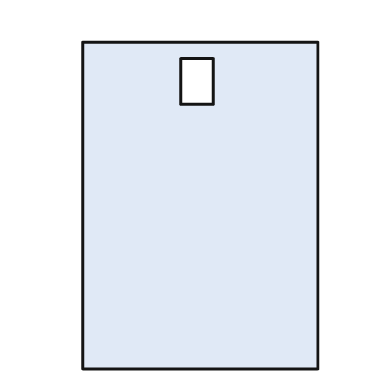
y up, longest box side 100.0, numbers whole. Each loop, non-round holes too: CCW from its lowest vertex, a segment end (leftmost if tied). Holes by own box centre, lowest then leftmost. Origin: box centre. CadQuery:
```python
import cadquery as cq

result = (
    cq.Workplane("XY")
    .moveTo(-36.0, -50.0)
    .lineTo(36.0, -50.0)
    .lineTo(36.0, 50.0)
    .lineTo(-36.0, 50.0)
    .close()
    .moveTo(-6.0, 31.0)
    .lineTo(4.0, 31.0)
    .lineTo(4.0, 45.0)
    .lineTo(-6.0, 45.0)
    .close()
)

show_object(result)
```